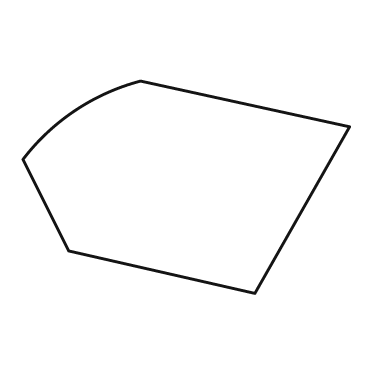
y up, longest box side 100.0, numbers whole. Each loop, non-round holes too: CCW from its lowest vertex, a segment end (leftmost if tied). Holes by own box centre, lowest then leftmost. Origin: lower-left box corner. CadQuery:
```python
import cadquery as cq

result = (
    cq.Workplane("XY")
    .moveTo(71.0, 0.0)
    .lineTo(100.0, 51.0)
    .lineTo(36.0, 65.0)
    .threePointArc((16.0, 56.0), (0.0, 41.0))
    .lineTo(14.0, 13.0)
    .close()
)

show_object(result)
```